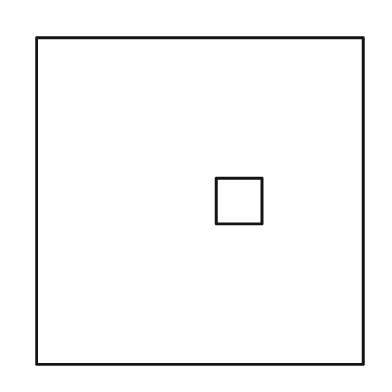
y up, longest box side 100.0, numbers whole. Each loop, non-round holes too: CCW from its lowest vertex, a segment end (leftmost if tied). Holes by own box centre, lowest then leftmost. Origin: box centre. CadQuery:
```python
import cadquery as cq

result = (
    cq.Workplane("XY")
    .moveTo(-50.0, -50.0)
    .lineTo(50.0, -50.0)
    .lineTo(50.0, 50.0)
    .lineTo(-50.0, 50.0)
    .close()
    .moveTo(5.0, -7.0)
    .lineTo(19.0, -7.0)
    .lineTo(19.0, 7.0)
    .lineTo(5.0, 7.0)
    .close()
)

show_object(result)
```